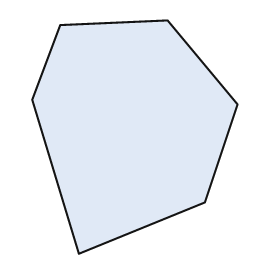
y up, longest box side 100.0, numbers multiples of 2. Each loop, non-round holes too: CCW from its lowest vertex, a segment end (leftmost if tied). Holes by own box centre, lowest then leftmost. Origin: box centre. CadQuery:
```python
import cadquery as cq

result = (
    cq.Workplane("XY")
    .moveTo(-24.0, -50.0)
    .lineTo(30.0, -28.0)
    .lineTo(44.0, 14.0)
    .lineTo(14.0, 50.0)
    .lineTo(-32.0, 48.0)
    .lineTo(-44.0, 16.0)
    .close()
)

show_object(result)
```